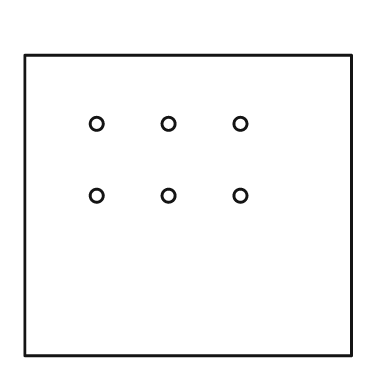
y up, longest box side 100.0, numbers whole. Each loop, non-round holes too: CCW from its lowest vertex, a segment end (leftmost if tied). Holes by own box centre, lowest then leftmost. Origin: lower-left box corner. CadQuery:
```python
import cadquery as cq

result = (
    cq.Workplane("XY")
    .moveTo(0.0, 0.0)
    .lineTo(100.0, 0.0)
    .lineTo(100.0, 92.0)
    .lineTo(0.0, 92.0)
    .close()
    .moveTo(22.0, 49.0)
    .circle(2.0)
    .moveTo(44.0, 49.0)
    .circle(2.0)
    .moveTo(66.0, 49.0)
    .circle(2.0)
    .moveTo(22.0, 71.0)
    .circle(2.0)
    .moveTo(44.0, 71.0)
    .circle(2.0)
    .moveTo(66.0, 71.0)
    .circle(2.0)
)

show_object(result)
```